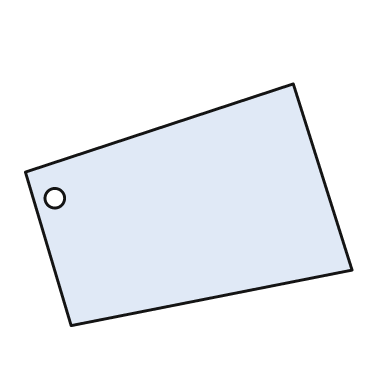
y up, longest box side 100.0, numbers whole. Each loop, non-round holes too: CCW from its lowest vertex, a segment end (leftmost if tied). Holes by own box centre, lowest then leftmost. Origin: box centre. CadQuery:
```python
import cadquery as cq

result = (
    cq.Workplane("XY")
    .moveTo(-36.0, -37.0)
    .lineTo(50.0, -20.0)
    .lineTo(32.0, 37.0)
    .lineTo(-50.0, 10.0)
    .close()
    .moveTo(-41.0, 2.0)
    .circle(3.0)
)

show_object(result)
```